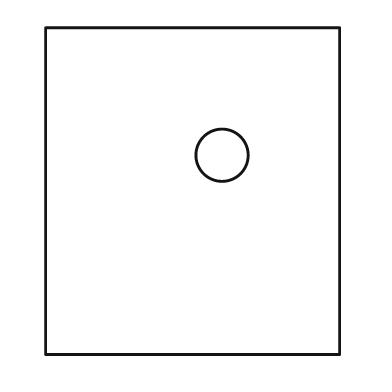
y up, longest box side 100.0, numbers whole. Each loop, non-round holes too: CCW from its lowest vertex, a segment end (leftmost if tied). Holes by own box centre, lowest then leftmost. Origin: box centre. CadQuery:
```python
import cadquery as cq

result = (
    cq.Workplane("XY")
    .moveTo(-45.0, -50.0)
    .lineTo(45.0, -50.0)
    .lineTo(45.0, 50.0)
    .lineTo(-45.0, 50.0)
    .close()
    .moveTo(9.0, 11.0)
    .circle(8.0)
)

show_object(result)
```